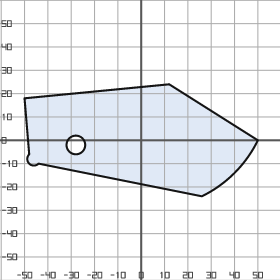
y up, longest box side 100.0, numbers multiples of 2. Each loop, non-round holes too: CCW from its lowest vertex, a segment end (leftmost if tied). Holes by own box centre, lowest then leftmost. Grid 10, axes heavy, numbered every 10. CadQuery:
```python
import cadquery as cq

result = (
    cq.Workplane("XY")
    .moveTo(26.0, -24.0)
    .threePointArc((40.0, -14.0), (50.0, 0.0))
    .lineTo(12.0, 24.0)
    .lineTo(-50.0, 18.0)
    .lineTo(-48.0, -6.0)
    .threePointArc((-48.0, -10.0), (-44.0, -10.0))
    .close()
    .moveTo(-28.0, -2.0)
    .circle(4.0)
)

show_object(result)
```